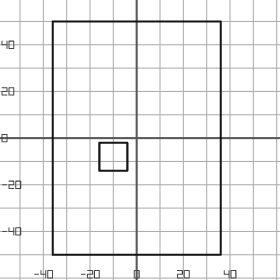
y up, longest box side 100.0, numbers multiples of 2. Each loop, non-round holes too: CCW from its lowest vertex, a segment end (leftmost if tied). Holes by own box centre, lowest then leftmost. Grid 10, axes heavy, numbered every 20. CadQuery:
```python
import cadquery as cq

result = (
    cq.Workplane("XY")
    .moveTo(-36.0, -50.0)
    .lineTo(36.0, -50.0)
    .lineTo(36.0, 50.0)
    .lineTo(-36.0, 50.0)
    .close()
    .moveTo(-16.0, -14.0)
    .lineTo(-4.0, -14.0)
    .lineTo(-4.0, -2.0)
    .lineTo(-16.0, -2.0)
    .close()
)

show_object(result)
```